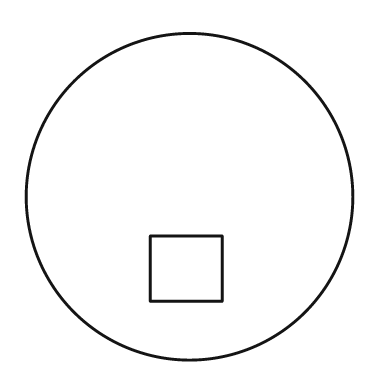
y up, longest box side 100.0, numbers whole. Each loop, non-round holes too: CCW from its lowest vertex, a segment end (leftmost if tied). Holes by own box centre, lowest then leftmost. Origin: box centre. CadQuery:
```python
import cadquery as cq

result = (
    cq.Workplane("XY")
    .moveTo(0.0, 0.0)
    .circle(50.0)
    .moveTo(-12.0, -32.0)
    .lineTo(10.0, -32.0)
    .lineTo(10.0, -12.0)
    .lineTo(-12.0, -12.0)
    .close()
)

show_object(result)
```